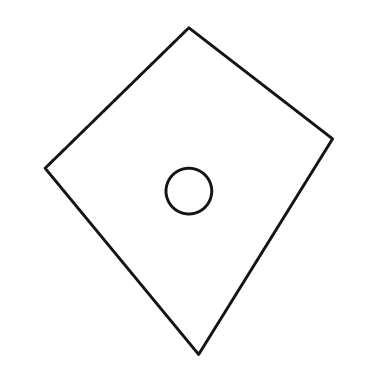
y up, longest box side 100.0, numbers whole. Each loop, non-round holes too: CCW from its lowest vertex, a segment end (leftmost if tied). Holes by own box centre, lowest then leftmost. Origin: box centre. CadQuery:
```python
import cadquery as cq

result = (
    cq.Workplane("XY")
    .moveTo(3.0, -50.0)
    .lineTo(44.0, 16.0)
    .lineTo(0.0, 50.0)
    .lineTo(-44.0, 7.0)
    .close()
    .moveTo(0.0, 0.0)
    .circle(7.0)
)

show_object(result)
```